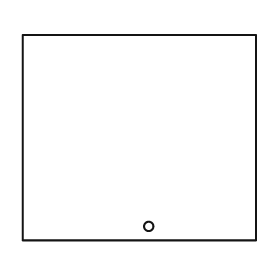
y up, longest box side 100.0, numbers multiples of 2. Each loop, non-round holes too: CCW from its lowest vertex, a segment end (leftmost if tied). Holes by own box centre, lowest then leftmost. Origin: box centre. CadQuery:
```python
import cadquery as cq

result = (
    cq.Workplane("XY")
    .moveTo(-50.0, -44.0)
    .lineTo(50.0, -44.0)
    .lineTo(50.0, 44.0)
    .lineTo(-50.0, 44.0)
    .close()
    .moveTo(4.0, -38.0)
    .circle(2.0)
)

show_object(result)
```